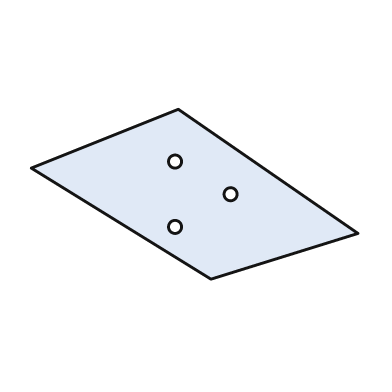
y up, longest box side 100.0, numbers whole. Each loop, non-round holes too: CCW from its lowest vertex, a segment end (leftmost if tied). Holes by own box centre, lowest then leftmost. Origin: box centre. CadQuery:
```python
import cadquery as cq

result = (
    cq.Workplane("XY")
    .moveTo(5.0, -26.0)
    .lineTo(50.0, -12.0)
    .lineTo(-5.0, 26.0)
    .lineTo(-50.0, 8.0)
    .close()
    .moveTo(-6.0, -10.0)
    .circle(2.0)
    .moveTo(11.0, 0.0)
    .circle(2.0)
    .moveTo(-6.0, 10.0)
    .circle(2.0)
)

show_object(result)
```